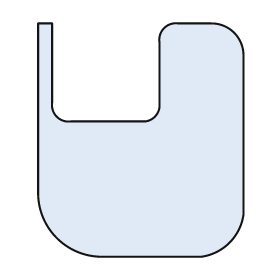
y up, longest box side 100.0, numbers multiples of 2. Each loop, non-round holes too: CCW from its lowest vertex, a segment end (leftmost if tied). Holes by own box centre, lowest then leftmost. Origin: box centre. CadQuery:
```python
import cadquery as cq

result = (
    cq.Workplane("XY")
    .moveTo(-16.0, -50.0)
    .lineTo(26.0, -50.0)
    .threePointArc((38.0, -44.0), (44.0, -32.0))
    .lineTo(44.0, 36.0)
    .threePointArc((40.0, 46.0), (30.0, 50.0))
    .lineTo(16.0, 50.0)
    .threePointArc((10.0, 48.0), (8.0, 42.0))
    .lineTo(8.0, 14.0)
    .threePointArc((6.0, 10.0), (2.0, 8.0))
    .lineTo(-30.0, 8.0)
    .threePointArc((-36.0, 10.0), (-38.0, 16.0))
    .lineTo(-38.0, 50.0)
    .lineTo(-44.0, 50.0)
    .lineTo(-44.0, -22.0)
    .threePointArc((-36.0, -42.0), (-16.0, -50.0))
    .close()
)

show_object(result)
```